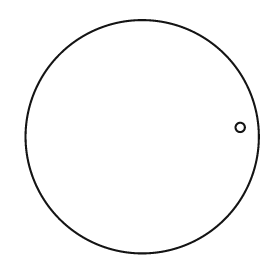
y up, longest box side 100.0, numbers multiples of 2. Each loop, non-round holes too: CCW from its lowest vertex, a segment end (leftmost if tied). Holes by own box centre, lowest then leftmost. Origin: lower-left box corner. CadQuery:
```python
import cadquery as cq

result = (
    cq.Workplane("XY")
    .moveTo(50.0, 50.0)
    .circle(50.0)
    .moveTo(92.0, 54.0)
    .circle(2.0)
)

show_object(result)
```